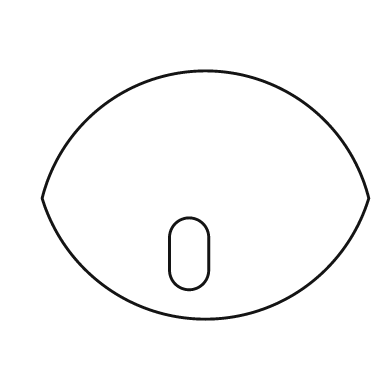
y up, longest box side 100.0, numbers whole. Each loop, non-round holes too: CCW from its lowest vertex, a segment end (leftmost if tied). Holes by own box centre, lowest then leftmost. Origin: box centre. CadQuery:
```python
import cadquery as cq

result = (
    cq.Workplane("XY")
    .moveTo(-50.0, -1.0)
    .threePointArc((0.0, -38.0), (50.0, -1.0))
    .threePointArc((0.0, 38.0), (-50.0, -1.0))
    .close()
    .moveTo(-11.0, -23.0)
    .threePointArc((-5.0, -29.0), (1.0, -23.0))
    .lineTo(1.0, -13.0)
    .threePointArc((-5.0, -7.0), (-11.0, -13.0))
    .close()
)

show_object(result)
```